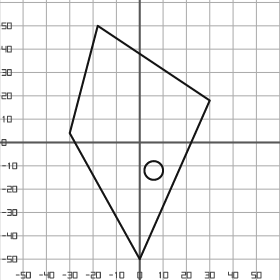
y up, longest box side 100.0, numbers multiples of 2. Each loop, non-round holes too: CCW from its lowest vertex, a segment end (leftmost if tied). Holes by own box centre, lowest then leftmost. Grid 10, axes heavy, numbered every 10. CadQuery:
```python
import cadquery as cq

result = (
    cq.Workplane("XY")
    .moveTo(0.0, -50.0)
    .lineTo(30.0, 18.0)
    .lineTo(-18.0, 50.0)
    .lineTo(-30.0, 4.0)
    .close()
    .moveTo(6.0, -12.0)
    .circle(4.0)
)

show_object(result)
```